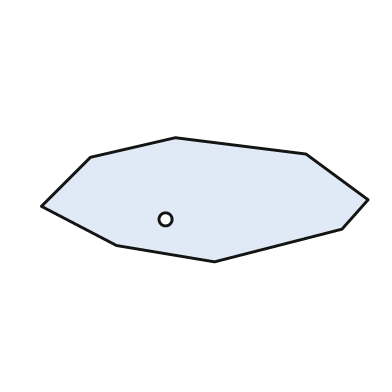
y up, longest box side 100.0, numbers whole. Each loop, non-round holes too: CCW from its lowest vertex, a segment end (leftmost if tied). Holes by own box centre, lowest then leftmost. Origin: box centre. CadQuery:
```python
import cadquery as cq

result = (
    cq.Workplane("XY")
    .moveTo(3.0, -19.0)
    .lineTo(42.0, -9.0)
    .lineTo(50.0, 0.0)
    .lineTo(31.0, 14.0)
    .lineTo(-9.0, 19.0)
    .lineTo(-35.0, 13.0)
    .lineTo(-50.0, -2.0)
    .lineTo(-27.0, -14.0)
    .close()
    .moveTo(-12.0, -6.0)
    .circle(2.0)
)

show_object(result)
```